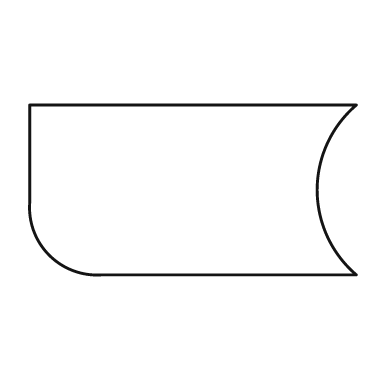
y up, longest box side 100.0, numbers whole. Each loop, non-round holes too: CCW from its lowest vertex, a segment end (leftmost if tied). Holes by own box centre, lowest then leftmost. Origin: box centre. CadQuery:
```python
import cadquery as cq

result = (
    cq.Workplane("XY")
    .moveTo(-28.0, -26.0)
    .lineTo(50.0, -26.0)
    .threePointArc((38.0, 0.0), (50.0, 26.0))
    .lineTo(-50.0, 26.0)
    .lineTo(-50.0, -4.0)
    .threePointArc((-44.0, -20.0), (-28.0, -26.0))
    .close()
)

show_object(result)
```